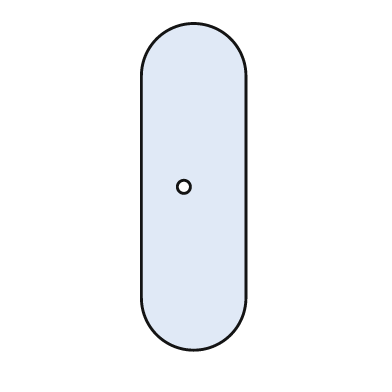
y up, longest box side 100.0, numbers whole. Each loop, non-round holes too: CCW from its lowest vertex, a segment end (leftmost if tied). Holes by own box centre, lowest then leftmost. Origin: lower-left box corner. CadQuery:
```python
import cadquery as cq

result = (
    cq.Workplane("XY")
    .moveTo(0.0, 16.0)
    .threePointArc((16.0, 0.0), (32.0, 16.0))
    .lineTo(32.0, 84.0)
    .threePointArc((16.0, 100.0), (0.0, 84.0))
    .close()
    .moveTo(13.0, 50.0)
    .circle(2.0)
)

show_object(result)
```